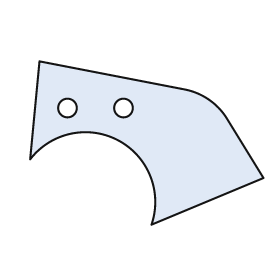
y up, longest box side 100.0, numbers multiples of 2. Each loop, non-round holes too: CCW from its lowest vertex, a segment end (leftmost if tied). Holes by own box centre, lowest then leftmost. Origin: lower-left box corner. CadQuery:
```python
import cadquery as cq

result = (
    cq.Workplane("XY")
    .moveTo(52.0, 0.0)
    .lineTo(100.0, 20.0)
    .lineTo(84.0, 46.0)
    .threePointArc((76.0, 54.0), (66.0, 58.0))
    .lineTo(4.0, 70.0)
    .lineTo(0.0, 28.0)
    .threePointArc((38.0, 36.0), (52.0, 0.0))
    .close()
    .moveTo(16.0, 50.0)
    .circle(4.0)
    .moveTo(40.0, 50.0)
    .circle(4.0)
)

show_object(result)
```